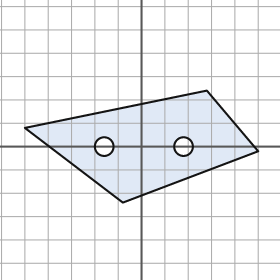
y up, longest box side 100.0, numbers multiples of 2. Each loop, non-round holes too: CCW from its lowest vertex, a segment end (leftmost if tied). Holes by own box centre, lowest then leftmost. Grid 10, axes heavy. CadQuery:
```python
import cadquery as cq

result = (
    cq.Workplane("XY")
    .moveTo(-8.0, -24.0)
    .lineTo(50.0, -2.0)
    .lineTo(28.0, 24.0)
    .lineTo(-50.0, 8.0)
    .close()
    .moveTo(-16.0, 0.0)
    .circle(4.0)
    .moveTo(18.0, 0.0)
    .circle(4.0)
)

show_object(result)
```